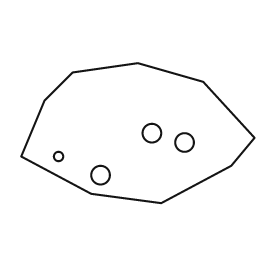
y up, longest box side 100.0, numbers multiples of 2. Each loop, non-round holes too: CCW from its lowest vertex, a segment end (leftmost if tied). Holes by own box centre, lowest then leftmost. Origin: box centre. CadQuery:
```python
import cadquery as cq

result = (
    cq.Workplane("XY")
    .moveTo(10.0, -30.0)
    .lineTo(40.0, -14.0)
    .lineTo(50.0, -2.0)
    .lineTo(28.0, 22.0)
    .lineTo(0.0, 30.0)
    .lineTo(-28.0, 26.0)
    .lineTo(-40.0, 14.0)
    .lineTo(-50.0, -10.0)
    .lineTo(-20.0, -26.0)
    .close()
    .moveTo(-16.0, -18.0)
    .circle(4.0)
    .moveTo(-34.0, -10.0)
    .circle(2.0)
    .moveTo(20.0, -4.0)
    .circle(4.0)
    .moveTo(6.0, 0.0)
    .circle(4.0)
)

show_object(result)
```